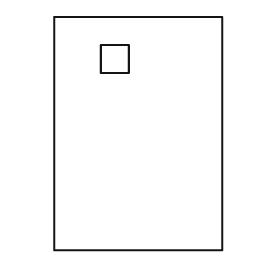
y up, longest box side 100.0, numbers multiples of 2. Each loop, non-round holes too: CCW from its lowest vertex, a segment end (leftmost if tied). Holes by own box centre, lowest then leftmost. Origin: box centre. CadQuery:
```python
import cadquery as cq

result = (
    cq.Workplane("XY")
    .moveTo(-36.0, -50.0)
    .lineTo(36.0, -50.0)
    .lineTo(36.0, 50.0)
    .lineTo(-36.0, 50.0)
    .close()
    .moveTo(-16.0, 26.0)
    .lineTo(-4.0, 26.0)
    .lineTo(-4.0, 38.0)
    .lineTo(-16.0, 38.0)
    .close()
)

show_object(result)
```